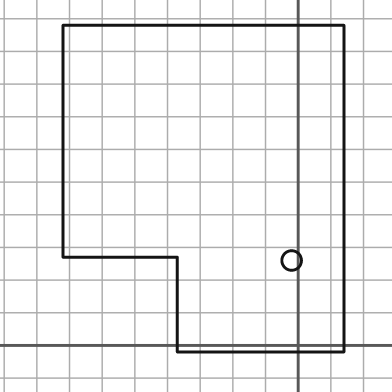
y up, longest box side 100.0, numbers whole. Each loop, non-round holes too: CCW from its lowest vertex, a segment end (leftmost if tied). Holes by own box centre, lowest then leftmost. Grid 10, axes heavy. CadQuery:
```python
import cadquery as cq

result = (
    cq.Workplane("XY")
    .moveTo(-37.0, -2.0)
    .lineTo(14.0, -2.0)
    .lineTo(14.0, 98.0)
    .lineTo(-72.0, 98.0)
    .lineTo(-72.0, 27.0)
    .lineTo(-37.0, 27.0)
    .close()
    .moveTo(-2.0, 26.0)
    .circle(3.0)
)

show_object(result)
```